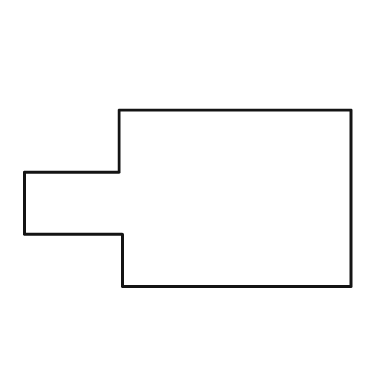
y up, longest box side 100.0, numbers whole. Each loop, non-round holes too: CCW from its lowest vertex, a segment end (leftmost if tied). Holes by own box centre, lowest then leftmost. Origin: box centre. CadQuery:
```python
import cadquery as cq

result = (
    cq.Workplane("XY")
    .moveTo(-20.0, -27.0)
    .lineTo(50.0, -27.0)
    .lineTo(50.0, 27.0)
    .lineTo(-21.0, 27.0)
    .lineTo(-21.0, 8.0)
    .lineTo(-50.0, 8.0)
    .lineTo(-50.0, -11.0)
    .lineTo(-20.0, -11.0)
    .close()
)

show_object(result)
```